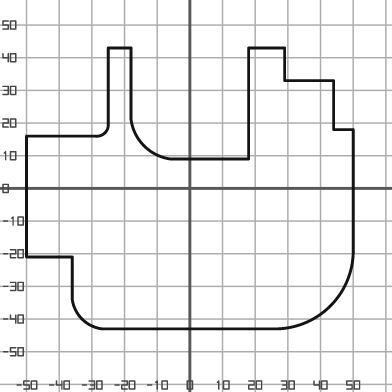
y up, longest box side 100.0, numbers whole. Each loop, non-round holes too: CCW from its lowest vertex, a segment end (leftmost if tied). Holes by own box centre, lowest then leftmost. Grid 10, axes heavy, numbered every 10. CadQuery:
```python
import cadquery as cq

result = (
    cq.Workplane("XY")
    .moveTo(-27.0, -43.0)
    .lineTo(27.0, -43.0)
    .threePointArc((43.0, -36.0), (50.0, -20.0))
    .lineTo(50.0, 18.0)
    .lineTo(44.0, 18.0)
    .lineTo(44.0, 33.0)
    .lineTo(29.0, 33.0)
    .lineTo(29.0, 43.0)
    .lineTo(18.0, 43.0)
    .lineTo(18.0, 9.0)
    .lineTo(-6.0, 9.0)
    .threePointArc((-14.0, 13.0), (-18.0, 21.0))
    .lineTo(-18.0, 43.0)
    .lineTo(-25.0, 43.0)
    .lineTo(-25.0, 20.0)
    .threePointArc((-26.0, 17.0), (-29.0, 16.0))
    .lineTo(-50.0, 16.0)
    .lineTo(-50.0, -21.0)
    .lineTo(-36.0, -21.0)
    .lineTo(-36.0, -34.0)
    .threePointArc((-33.0, -40.0), (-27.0, -43.0))
    .close()
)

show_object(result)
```